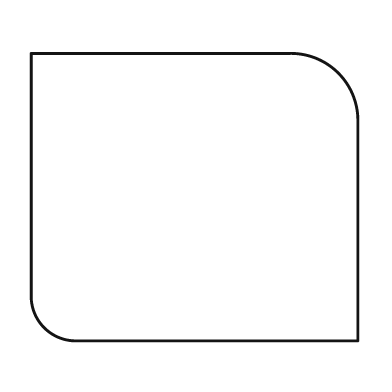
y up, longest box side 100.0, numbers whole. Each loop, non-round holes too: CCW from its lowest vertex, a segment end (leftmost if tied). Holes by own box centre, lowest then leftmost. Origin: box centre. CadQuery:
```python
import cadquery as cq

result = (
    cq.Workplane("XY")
    .moveTo(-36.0, -44.0)
    .lineTo(50.0, -44.0)
    .lineTo(50.0, 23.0)
    .threePointArc((44.0, 38.0), (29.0, 44.0))
    .lineTo(-50.0, 44.0)
    .lineTo(-50.0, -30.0)
    .threePointArc((-46.0, -40.0), (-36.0, -44.0))
    .close()
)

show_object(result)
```